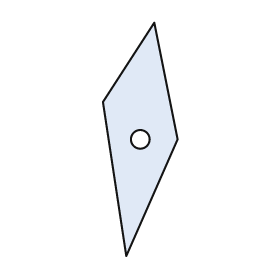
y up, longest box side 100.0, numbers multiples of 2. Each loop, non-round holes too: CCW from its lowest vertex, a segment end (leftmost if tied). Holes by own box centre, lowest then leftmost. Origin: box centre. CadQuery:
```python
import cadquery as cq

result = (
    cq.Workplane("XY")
    .moveTo(-6.0, -50.0)
    .lineTo(16.0, 0.0)
    .lineTo(6.0, 50.0)
    .lineTo(-16.0, 16.0)
    .close()
    .moveTo(0.0, 0.0)
    .circle(4.0)
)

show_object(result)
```